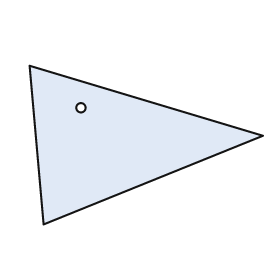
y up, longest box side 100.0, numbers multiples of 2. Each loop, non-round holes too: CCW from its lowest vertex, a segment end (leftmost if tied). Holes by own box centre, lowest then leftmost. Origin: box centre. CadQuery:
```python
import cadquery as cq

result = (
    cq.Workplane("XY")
    .moveTo(-44.0, -34.0)
    .lineTo(50.0, 4.0)
    .lineTo(-50.0, 34.0)
    .close()
    .moveTo(-28.0, 16.0)
    .circle(2.0)
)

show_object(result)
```